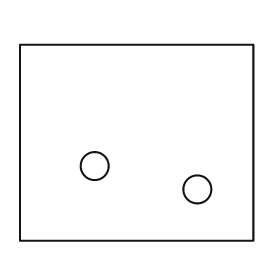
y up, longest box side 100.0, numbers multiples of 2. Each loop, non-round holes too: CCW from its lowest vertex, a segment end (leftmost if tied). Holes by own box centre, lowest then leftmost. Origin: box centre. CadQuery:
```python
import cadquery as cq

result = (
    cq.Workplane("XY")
    .moveTo(-50.0, -42.0)
    .lineTo(50.0, -42.0)
    .lineTo(50.0, 42.0)
    .lineTo(-50.0, 42.0)
    .close()
    .moveTo(26.0, -20.0)
    .circle(6.0)
    .moveTo(-18.0, -10.0)
    .circle(6.0)
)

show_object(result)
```